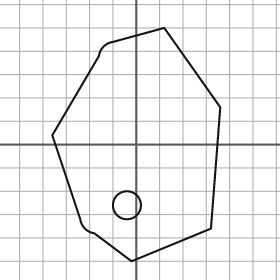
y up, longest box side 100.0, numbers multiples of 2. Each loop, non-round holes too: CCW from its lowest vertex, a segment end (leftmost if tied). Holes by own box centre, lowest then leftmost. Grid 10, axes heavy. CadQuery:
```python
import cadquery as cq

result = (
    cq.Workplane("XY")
    .moveTo(-2.0, -50.0)
    .lineTo(32.0, -36.0)
    .lineTo(36.0, 16.0)
    .lineTo(12.0, 50.0)
    .lineTo(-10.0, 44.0)
    .threePointArc((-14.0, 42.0), (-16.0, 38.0))
    .lineTo(-36.0, 4.0)
    .lineTo(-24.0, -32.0)
    .threePointArc((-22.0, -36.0), (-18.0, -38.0))
    .close()
    .moveTo(-4.0, -26.0)
    .circle(6.0)
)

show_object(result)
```